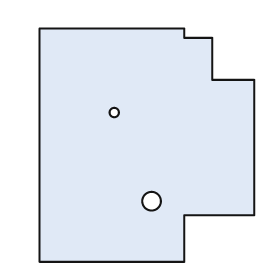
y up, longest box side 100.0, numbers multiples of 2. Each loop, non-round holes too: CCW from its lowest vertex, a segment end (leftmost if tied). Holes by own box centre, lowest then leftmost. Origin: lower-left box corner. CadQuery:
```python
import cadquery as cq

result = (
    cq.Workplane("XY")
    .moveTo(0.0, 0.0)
    .lineTo(62.0, 0.0)
    .lineTo(62.0, 20.0)
    .lineTo(92.0, 20.0)
    .lineTo(92.0, 78.0)
    .lineTo(74.0, 78.0)
    .lineTo(74.0, 96.0)
    .lineTo(62.0, 96.0)
    .lineTo(62.0, 100.0)
    .lineTo(0.0, 100.0)
    .close()
    .moveTo(48.0, 26.0)
    .circle(4.0)
    .moveTo(32.0, 64.0)
    .circle(2.0)
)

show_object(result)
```